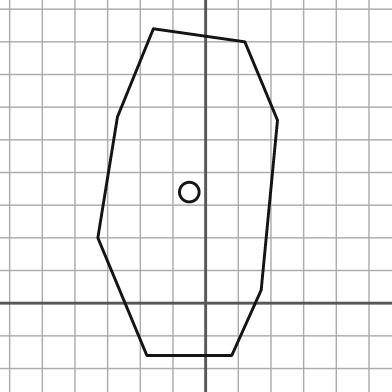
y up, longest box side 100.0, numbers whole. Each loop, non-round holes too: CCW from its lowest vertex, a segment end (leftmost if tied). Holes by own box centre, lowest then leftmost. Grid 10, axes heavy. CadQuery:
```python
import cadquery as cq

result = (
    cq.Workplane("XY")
    .moveTo(-18.0, -16.0)
    .lineTo(8.0, -16.0)
    .lineTo(17.0, 4.0)
    .lineTo(22.0, 56.0)
    .lineTo(12.0, 80.0)
    .lineTo(-16.0, 84.0)
    .lineTo(-27.0, 57.0)
    .lineTo(-33.0, 20.0)
    .close()
    .moveTo(-5.0, 34.0)
    .circle(3.0)
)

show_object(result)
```